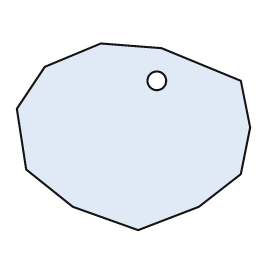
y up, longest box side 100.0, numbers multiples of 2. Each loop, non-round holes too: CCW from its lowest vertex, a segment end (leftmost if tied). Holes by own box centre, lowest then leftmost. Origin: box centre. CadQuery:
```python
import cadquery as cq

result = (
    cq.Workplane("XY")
    .moveTo(2.0, -40.0)
    .lineTo(28.0, -30.0)
    .lineTo(46.0, -16.0)
    .lineTo(50.0, 4.0)
    .lineTo(46.0, 24.0)
    .lineTo(12.0, 38.0)
    .lineTo(-14.0, 40.0)
    .lineTo(-38.0, 30.0)
    .lineTo(-50.0, 12.0)
    .lineTo(-46.0, -14.0)
    .lineTo(-26.0, -30.0)
    .close()
    .moveTo(10.0, 24.0)
    .circle(4.0)
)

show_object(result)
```